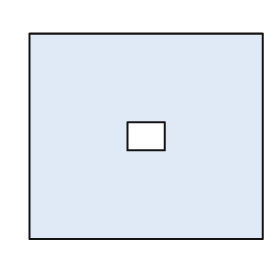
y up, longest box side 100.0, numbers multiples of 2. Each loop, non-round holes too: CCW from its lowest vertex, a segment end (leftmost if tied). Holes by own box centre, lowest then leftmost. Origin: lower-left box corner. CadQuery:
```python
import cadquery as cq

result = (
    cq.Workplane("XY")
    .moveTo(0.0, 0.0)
    .lineTo(100.0, 0.0)
    .lineTo(100.0, 88.0)
    .lineTo(0.0, 88.0)
    .close()
    .moveTo(42.0, 38.0)
    .lineTo(58.0, 38.0)
    .lineTo(58.0, 50.0)
    .lineTo(42.0, 50.0)
    .close()
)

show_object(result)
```